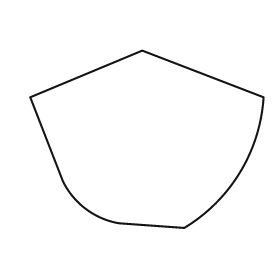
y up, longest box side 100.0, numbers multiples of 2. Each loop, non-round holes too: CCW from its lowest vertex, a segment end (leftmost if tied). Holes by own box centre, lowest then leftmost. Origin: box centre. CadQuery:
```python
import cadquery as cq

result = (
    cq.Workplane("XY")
    .moveTo(16.0, -38.0)
    .threePointArc((40.0, -14.0), (50.0, 18.0))
    .lineTo(-2.0, 38.0)
    .lineTo(-50.0, 18.0)
    .lineTo(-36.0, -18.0)
    .threePointArc((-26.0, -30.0), (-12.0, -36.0))
    .close()
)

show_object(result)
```